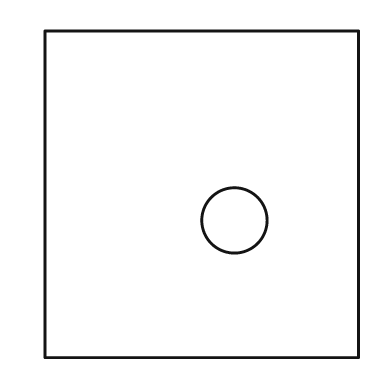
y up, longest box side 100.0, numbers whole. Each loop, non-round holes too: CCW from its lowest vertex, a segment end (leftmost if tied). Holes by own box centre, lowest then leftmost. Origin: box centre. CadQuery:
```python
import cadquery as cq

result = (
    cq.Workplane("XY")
    .moveTo(-48.0, -50.0)
    .lineTo(48.0, -50.0)
    .lineTo(48.0, 50.0)
    .lineTo(-48.0, 50.0)
    .close()
    .moveTo(10.0, -8.0)
    .circle(10.0)
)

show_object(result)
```